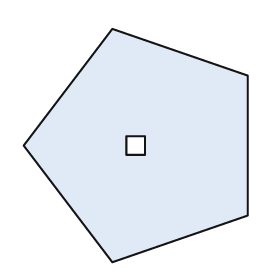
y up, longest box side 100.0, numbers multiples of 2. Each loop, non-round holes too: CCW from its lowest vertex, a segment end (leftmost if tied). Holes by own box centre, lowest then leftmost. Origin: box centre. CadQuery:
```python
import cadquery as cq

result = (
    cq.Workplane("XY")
    .moveTo(-10.0, -50.0)
    .lineTo(48.0, -30.0)
    .lineTo(48.0, 30.0)
    .lineTo(-10.0, 50.0)
    .lineTo(-48.0, 0.0)
    .close()
    .moveTo(-4.0, -4.0)
    .lineTo(4.0, -4.0)
    .lineTo(4.0, 4.0)
    .lineTo(-4.0, 4.0)
    .close()
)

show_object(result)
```